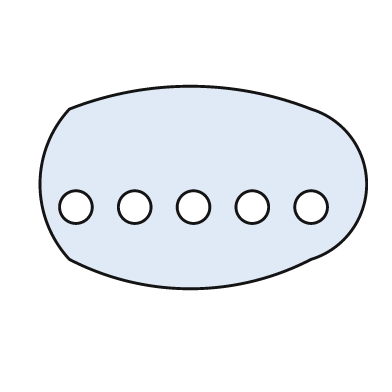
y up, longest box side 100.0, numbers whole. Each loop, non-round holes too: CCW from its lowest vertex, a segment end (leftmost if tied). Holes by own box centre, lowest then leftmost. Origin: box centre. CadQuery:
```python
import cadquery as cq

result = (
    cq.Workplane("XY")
    .moveTo(-41.0, -22.0)
    .threePointArc((-4.0, -31.0), (33.0, -22.0))
    .threePointArc((50.0, 1.0), (33.0, 24.0))
    .threePointArc((-4.0, 31.0), (-41.0, 24.0))
    .threePointArc((-50.0, 1.0), (-41.0, -22.0))
    .close()
    .moveTo(-39.0, -6.0)
    .circle(5.0)
    .moveTo(-21.0, -6.0)
    .circle(5.0)
    .moveTo(-3.0, -6.0)
    .circle(5.0)
    .moveTo(15.0, -6.0)
    .circle(5.0)
    .moveTo(33.0, -6.0)
    .circle(5.0)
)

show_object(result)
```